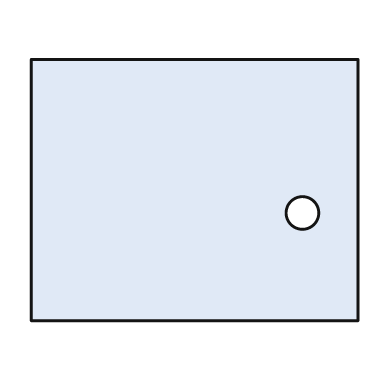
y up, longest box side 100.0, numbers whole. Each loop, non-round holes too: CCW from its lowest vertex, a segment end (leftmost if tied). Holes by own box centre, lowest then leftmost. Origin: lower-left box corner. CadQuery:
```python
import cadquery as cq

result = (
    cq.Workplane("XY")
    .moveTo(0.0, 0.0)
    .lineTo(100.0, 0.0)
    .lineTo(100.0, 80.0)
    .lineTo(0.0, 80.0)
    .close()
    .moveTo(83.0, 33.0)
    .circle(5.0)
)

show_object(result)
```